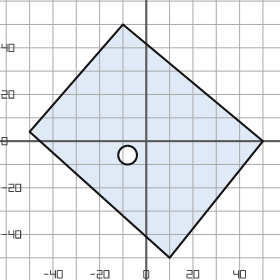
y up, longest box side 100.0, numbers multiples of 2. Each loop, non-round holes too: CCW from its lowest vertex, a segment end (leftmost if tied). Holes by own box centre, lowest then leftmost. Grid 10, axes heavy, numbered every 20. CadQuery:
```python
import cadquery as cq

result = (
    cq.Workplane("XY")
    .moveTo(10.0, -50.0)
    .lineTo(50.0, 0.0)
    .lineTo(-10.0, 50.0)
    .lineTo(-50.0, 4.0)
    .close()
    .moveTo(-8.0, -6.0)
    .circle(4.0)
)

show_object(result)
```